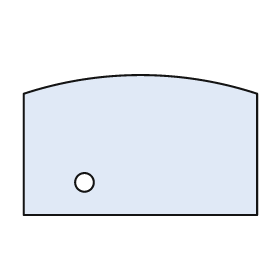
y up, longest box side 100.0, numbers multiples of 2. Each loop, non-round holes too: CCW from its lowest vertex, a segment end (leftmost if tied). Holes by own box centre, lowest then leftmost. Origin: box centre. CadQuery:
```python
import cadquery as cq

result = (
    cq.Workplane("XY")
    .moveTo(-50.0, -30.0)
    .lineTo(50.0, -30.0)
    .lineTo(50.0, 22.0)
    .threePointArc((0.0, 30.0), (-50.0, 22.0))
    .close()
    .moveTo(-24.0, -16.0)
    .circle(4.0)
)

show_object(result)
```